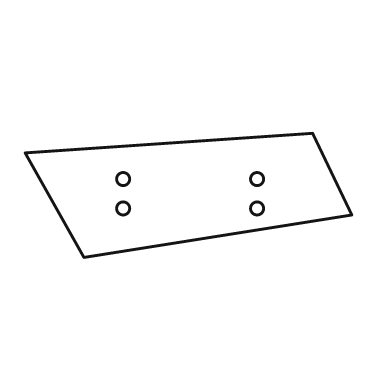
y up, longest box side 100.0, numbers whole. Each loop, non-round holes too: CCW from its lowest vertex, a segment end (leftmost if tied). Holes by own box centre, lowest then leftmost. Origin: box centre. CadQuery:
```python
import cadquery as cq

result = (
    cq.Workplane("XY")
    .moveTo(-32.0, -19.0)
    .lineTo(50.0, -6.0)
    .lineTo(38.0, 19.0)
    .lineTo(-50.0, 13.0)
    .close()
    .moveTo(-20.0, -4.0)
    .circle(2.0)
    .moveTo(21.0, -4.0)
    .circle(2.0)
    .moveTo(-20.0, 5.0)
    .circle(2.0)
    .moveTo(21.0, 5.0)
    .circle(2.0)
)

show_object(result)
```